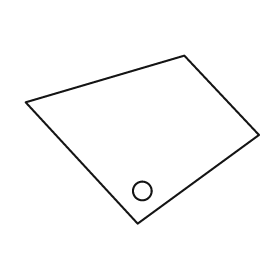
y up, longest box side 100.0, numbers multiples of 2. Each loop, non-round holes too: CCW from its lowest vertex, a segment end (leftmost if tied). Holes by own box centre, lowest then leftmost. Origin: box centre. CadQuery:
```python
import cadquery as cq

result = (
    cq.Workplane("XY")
    .moveTo(-2.0, -36.0)
    .lineTo(50.0, 2.0)
    .lineTo(18.0, 36.0)
    .lineTo(-50.0, 16.0)
    .close()
    .moveTo(0.0, -22.0)
    .circle(4.0)
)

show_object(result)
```